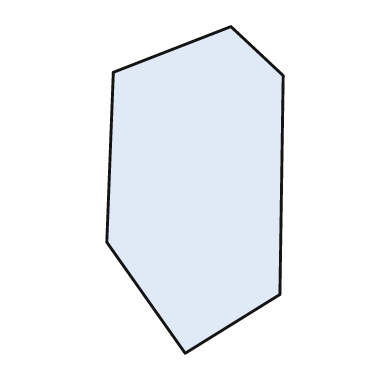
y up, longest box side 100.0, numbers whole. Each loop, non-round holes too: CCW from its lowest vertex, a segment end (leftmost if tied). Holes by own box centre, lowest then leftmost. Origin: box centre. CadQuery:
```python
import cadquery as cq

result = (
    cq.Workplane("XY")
    .moveTo(-3.0, -50.0)
    .lineTo(26.0, -32.0)
    .lineTo(27.0, 35.0)
    .lineTo(11.0, 50.0)
    .lineTo(-25.0, 36.0)
    .lineTo(-27.0, -16.0)
    .close()
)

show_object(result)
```